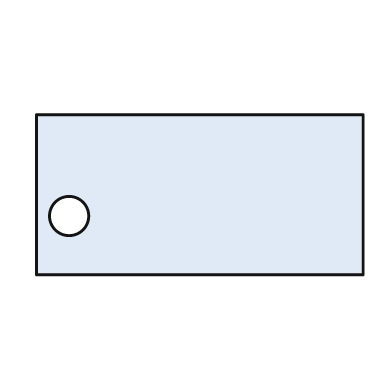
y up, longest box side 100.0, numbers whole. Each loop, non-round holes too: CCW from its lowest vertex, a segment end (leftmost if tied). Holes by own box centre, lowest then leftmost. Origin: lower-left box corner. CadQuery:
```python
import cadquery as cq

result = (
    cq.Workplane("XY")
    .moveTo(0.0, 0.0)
    .lineTo(100.0, 0.0)
    .lineTo(100.0, 49.0)
    .lineTo(0.0, 49.0)
    .close()
    .moveTo(10.0, 18.0)
    .circle(6.0)
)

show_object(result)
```